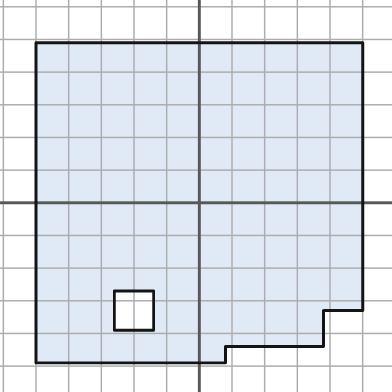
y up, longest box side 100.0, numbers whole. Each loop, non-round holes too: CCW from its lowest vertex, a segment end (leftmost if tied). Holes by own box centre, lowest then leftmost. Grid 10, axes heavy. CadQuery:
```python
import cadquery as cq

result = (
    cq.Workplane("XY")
    .moveTo(-50.0, -49.0)
    .lineTo(8.0, -49.0)
    .lineTo(8.0, -44.0)
    .lineTo(38.0, -44.0)
    .lineTo(38.0, -33.0)
    .lineTo(50.0, -33.0)
    .lineTo(50.0, 49.0)
    .lineTo(-50.0, 49.0)
    .close()
    .moveTo(-26.0, -39.0)
    .lineTo(-14.0, -39.0)
    .lineTo(-14.0, -27.0)
    .lineTo(-26.0, -27.0)
    .close()
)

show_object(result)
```